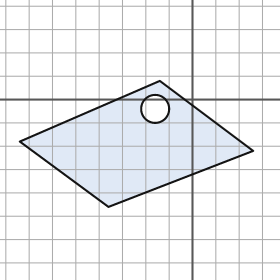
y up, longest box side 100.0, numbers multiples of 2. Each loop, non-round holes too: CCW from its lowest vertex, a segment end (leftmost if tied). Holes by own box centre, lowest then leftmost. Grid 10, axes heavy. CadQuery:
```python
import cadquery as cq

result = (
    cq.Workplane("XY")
    .moveTo(-36.0, -46.0)
    .lineTo(26.0, -22.0)
    .lineTo(-14.0, 8.0)
    .lineTo(-74.0, -18.0)
    .close()
    .moveTo(-16.0, -4.0)
    .circle(6.0)
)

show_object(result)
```